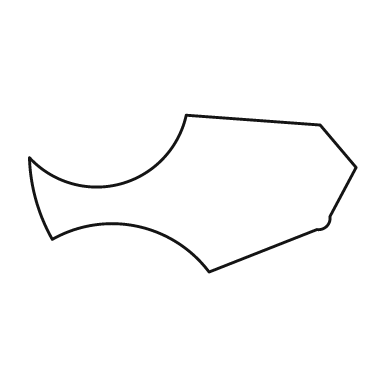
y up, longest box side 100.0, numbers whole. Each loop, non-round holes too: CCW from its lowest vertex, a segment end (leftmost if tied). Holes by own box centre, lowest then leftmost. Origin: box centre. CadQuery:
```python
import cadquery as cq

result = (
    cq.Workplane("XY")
    .moveTo(5.0, -24.0)
    .lineTo(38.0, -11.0)
    .threePointArc((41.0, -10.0), (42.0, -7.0))
    .lineTo(50.0, 8.0)
    .lineTo(39.0, 21.0)
    .lineTo(-2.0, 24.0)
    .threePointArc((-22.0, 3.0), (-50.0, 11.0))
    .threePointArc((-48.0, -2.0), (-43.0, -14.0))
    .threePointArc((-17.0, -10.0), (5.0, -24.0))
    .close()
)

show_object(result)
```